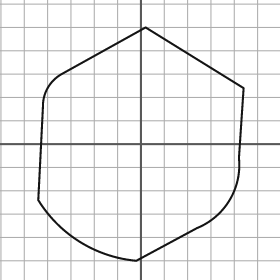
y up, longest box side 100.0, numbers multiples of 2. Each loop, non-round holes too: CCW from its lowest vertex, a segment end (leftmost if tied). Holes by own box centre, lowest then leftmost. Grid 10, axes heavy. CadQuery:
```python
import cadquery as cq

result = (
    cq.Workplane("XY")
    .moveTo(-2.0, -50.0)
    .lineTo(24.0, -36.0)
    .threePointArc((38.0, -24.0), (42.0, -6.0))
    .lineTo(44.0, 24.0)
    .lineTo(2.0, 50.0)
    .lineTo(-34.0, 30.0)
    .threePointArc((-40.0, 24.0), (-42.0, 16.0))
    .lineTo(-44.0, -24.0)
    .threePointArc((-26.0, -42.0), (-2.0, -50.0))
    .close()
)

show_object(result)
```